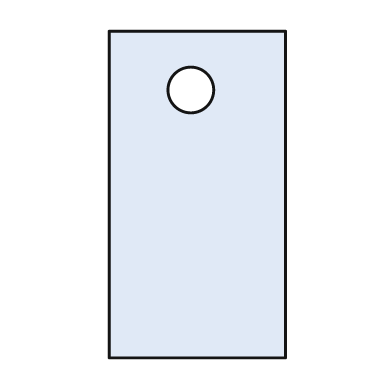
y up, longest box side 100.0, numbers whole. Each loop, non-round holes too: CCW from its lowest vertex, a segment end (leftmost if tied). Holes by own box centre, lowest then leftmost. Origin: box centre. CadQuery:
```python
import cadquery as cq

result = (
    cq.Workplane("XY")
    .moveTo(-27.0, -50.0)
    .lineTo(27.0, -50.0)
    .lineTo(27.0, 50.0)
    .lineTo(-27.0, 50.0)
    .close()
    .moveTo(-2.0, 32.0)
    .circle(7.0)
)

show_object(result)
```